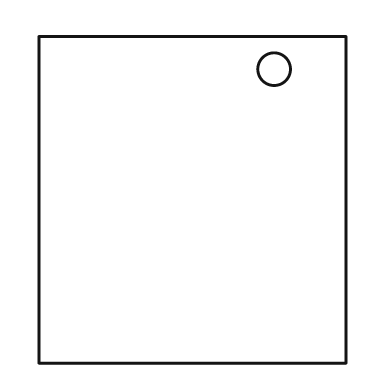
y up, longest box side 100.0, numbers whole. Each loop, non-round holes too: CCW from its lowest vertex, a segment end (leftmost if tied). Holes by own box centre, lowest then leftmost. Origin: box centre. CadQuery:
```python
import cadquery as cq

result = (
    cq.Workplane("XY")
    .moveTo(-47.0, -50.0)
    .lineTo(47.0, -50.0)
    .lineTo(47.0, 50.0)
    .lineTo(-47.0, 50.0)
    .close()
    .moveTo(25.0, 40.0)
    .circle(5.0)
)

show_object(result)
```